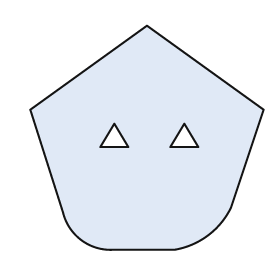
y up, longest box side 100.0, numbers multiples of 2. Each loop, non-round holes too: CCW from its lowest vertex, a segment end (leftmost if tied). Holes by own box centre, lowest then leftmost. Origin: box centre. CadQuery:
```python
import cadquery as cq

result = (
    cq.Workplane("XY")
    .moveTo(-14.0, -48.0)
    .lineTo(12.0, -48.0)
    .threePointArc((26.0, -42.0), (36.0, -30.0))
    .lineTo(50.0, 12.0)
    .lineTo(0.0, 48.0)
    .lineTo(-50.0, 12.0)
    .lineTo(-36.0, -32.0)
    .threePointArc((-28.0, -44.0), (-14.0, -48.0))
    .close()
    .moveTo(-20.0, -4.0)
    .lineTo(-8.0, -4.0)
    .lineTo(-14.0, 6.0)
    .close()
    .moveTo(10.0, -4.0)
    .lineTo(22.0, -4.0)
    .lineTo(16.0, 6.0)
    .close()
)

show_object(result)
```